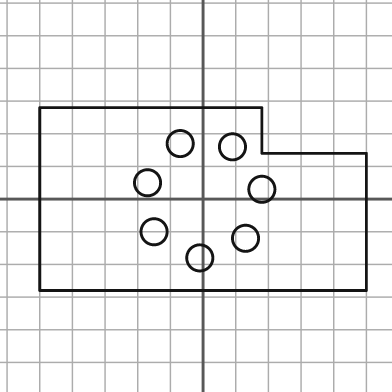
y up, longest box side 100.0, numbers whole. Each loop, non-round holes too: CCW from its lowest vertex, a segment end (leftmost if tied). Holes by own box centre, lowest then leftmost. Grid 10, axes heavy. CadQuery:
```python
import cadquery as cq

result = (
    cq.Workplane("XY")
    .moveTo(-50.0, -28.0)
    .lineTo(50.0, -28.0)
    .lineTo(50.0, 14.0)
    .lineTo(18.0, 14.0)
    .lineTo(18.0, 28.0)
    .lineTo(-50.0, 28.0)
    .close()
    .moveTo(-1.0, -18.0)
    .circle(4.0)
    .moveTo(13.0, -12.0)
    .circle(4.0)
    .moveTo(-15.0, -10.0)
    .circle(4.0)
    .moveTo(18.0, 3.0)
    .circle(4.0)
    .moveTo(-17.0, 5.0)
    .circle(4.0)
    .moveTo(9.0, 16.0)
    .circle(4.0)
    .moveTo(-7.0, 17.0)
    .circle(4.0)
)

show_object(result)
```